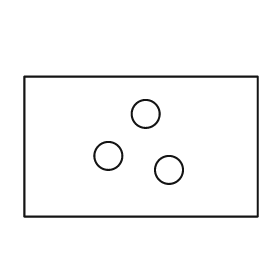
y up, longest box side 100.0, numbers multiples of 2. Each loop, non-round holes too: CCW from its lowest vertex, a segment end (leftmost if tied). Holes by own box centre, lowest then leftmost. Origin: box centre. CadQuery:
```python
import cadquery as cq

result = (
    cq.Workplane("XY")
    .moveTo(-50.0, -30.0)
    .lineTo(50.0, -30.0)
    .lineTo(50.0, 30.0)
    .lineTo(-50.0, 30.0)
    .close()
    .moveTo(12.0, -10.0)
    .circle(6.0)
    .moveTo(-14.0, -4.0)
    .circle(6.0)
    .moveTo(2.0, 14.0)
    .circle(6.0)
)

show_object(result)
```